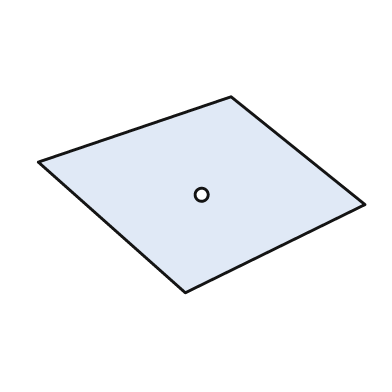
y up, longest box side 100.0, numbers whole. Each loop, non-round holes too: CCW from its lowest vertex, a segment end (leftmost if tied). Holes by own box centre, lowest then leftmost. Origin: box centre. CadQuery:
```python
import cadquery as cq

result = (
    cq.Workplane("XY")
    .moveTo(-5.0, -30.0)
    .lineTo(50.0, -3.0)
    .lineTo(9.0, 30.0)
    .lineTo(-50.0, 10.0)
    .close()
    .moveTo(0.0, 0.0)
    .circle(2.0)
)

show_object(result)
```